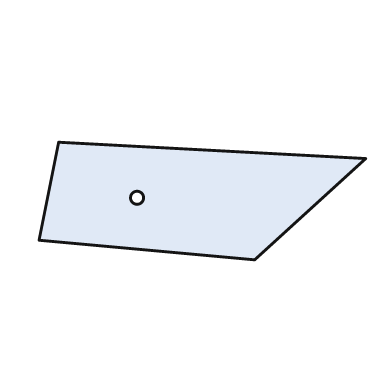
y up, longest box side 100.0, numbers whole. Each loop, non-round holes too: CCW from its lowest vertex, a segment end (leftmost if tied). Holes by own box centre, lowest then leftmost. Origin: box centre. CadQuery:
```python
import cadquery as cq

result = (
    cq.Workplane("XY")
    .moveTo(16.0, -18.0)
    .lineTo(50.0, 13.0)
    .lineTo(-44.0, 18.0)
    .lineTo(-50.0, -12.0)
    .close()
    .moveTo(-20.0, 1.0)
    .circle(2.0)
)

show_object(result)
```